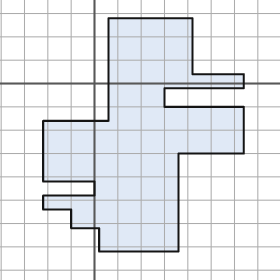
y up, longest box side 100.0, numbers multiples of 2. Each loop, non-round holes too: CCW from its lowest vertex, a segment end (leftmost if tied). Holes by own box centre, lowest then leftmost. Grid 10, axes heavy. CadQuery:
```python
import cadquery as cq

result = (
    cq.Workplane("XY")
    .moveTo(2.0, -72.0)
    .lineTo(36.0, -72.0)
    .lineTo(36.0, -30.0)
    .lineTo(64.0, -30.0)
    .lineTo(64.0, -10.0)
    .lineTo(30.0, -10.0)
    .lineTo(30.0, -2.0)
    .lineTo(64.0, -2.0)
    .lineTo(64.0, 4.0)
    .lineTo(42.0, 4.0)
    .lineTo(42.0, 28.0)
    .lineTo(6.0, 28.0)
    .lineTo(6.0, -16.0)
    .lineTo(-22.0, -16.0)
    .lineTo(-22.0, -42.0)
    .lineTo(0.0, -42.0)
    .lineTo(0.0, -48.0)
    .lineTo(-22.0, -48.0)
    .lineTo(-22.0, -54.0)
    .lineTo(-10.0, -54.0)
    .lineTo(-10.0, -62.0)
    .lineTo(2.0, -62.0)
    .close()
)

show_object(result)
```